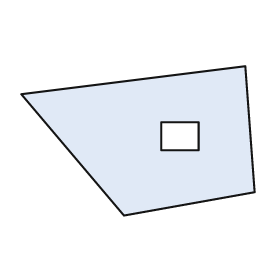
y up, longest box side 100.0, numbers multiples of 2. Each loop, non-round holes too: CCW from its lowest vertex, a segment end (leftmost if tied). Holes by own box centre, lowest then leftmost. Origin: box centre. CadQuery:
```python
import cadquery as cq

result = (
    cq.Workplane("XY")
    .moveTo(-6.0, -32.0)
    .lineTo(50.0, -22.0)
    .lineTo(46.0, 32.0)
    .lineTo(-50.0, 20.0)
    .close()
    .moveTo(10.0, -4.0)
    .lineTo(26.0, -4.0)
    .lineTo(26.0, 8.0)
    .lineTo(10.0, 8.0)
    .close()
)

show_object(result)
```